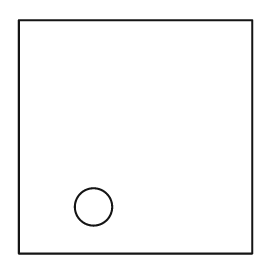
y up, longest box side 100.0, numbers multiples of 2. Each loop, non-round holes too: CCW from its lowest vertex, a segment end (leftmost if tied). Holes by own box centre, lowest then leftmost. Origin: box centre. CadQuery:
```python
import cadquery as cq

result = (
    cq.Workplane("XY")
    .moveTo(-50.0, -50.0)
    .lineTo(50.0, -50.0)
    .lineTo(50.0, 50.0)
    .lineTo(-50.0, 50.0)
    .close()
    .moveTo(-18.0, -30.0)
    .circle(8.0)
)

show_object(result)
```